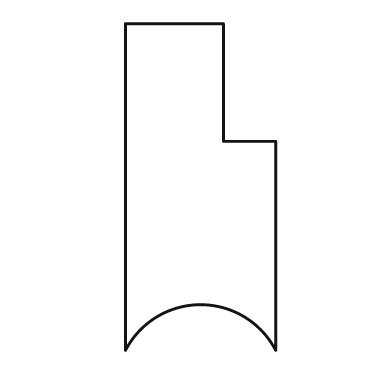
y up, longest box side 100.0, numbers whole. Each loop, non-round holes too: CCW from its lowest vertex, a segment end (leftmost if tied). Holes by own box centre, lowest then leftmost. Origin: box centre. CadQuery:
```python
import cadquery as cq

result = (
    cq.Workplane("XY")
    .moveTo(-23.0, -50.0)
    .threePointArc((0.0, -36.0), (23.0, -50.0))
    .lineTo(23.0, 14.0)
    .lineTo(7.0, 14.0)
    .lineTo(7.0, 50.0)
    .lineTo(-23.0, 50.0)
    .close()
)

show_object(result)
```